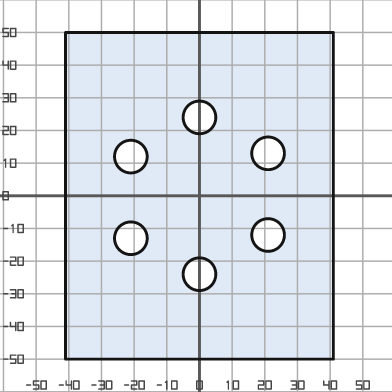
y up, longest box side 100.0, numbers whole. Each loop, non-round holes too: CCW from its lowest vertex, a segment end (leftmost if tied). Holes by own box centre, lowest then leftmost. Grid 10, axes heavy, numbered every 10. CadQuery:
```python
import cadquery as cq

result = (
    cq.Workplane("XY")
    .moveTo(-41.0, -50.0)
    .lineTo(41.0, -50.0)
    .lineTo(41.0, 50.0)
    .lineTo(-41.0, 50.0)
    .close()
    .moveTo(0.0, -24.0)
    .circle(5.0)
    .moveTo(-21.0, -13.0)
    .circle(5.0)
    .moveTo(21.0, -12.0)
    .circle(5.0)
    .moveTo(-21.0, 12.0)
    .circle(5.0)
    .moveTo(21.0, 13.0)
    .circle(5.0)
    .moveTo(0.0, 24.0)
    .circle(5.0)
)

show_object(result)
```